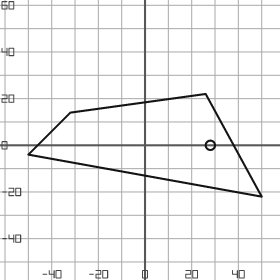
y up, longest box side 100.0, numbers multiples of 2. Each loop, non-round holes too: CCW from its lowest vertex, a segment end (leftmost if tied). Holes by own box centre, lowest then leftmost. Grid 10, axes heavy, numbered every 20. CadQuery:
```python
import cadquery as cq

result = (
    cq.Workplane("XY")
    .moveTo(50.0, -22.0)
    .lineTo(26.0, 22.0)
    .lineTo(-32.0, 14.0)
    .lineTo(-50.0, -4.0)
    .close()
    .moveTo(28.0, 0.0)
    .circle(2.0)
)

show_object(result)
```